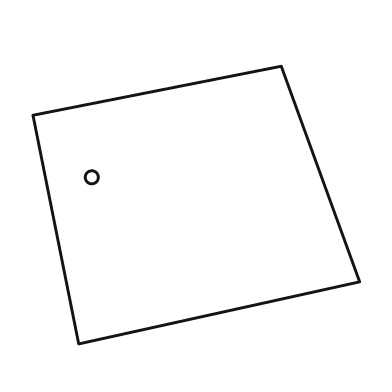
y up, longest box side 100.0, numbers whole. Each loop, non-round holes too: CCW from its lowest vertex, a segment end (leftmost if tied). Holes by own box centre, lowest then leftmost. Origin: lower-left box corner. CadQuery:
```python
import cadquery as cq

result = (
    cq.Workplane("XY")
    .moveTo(14.0, 0.0)
    .lineTo(100.0, 19.0)
    .lineTo(76.0, 85.0)
    .lineTo(0.0, 70.0)
    .close()
    .moveTo(18.0, 51.0)
    .circle(2.0)
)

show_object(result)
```